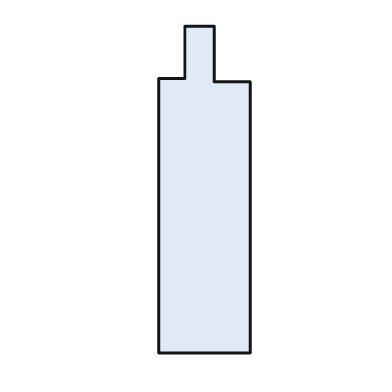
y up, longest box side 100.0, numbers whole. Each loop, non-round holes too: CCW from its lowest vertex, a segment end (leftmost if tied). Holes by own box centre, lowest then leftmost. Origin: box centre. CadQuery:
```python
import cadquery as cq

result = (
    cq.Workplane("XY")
    .moveTo(-14.0, -50.0)
    .lineTo(14.0, -50.0)
    .lineTo(14.0, 33.0)
    .lineTo(3.0, 33.0)
    .lineTo(3.0, 50.0)
    .lineTo(-6.0, 50.0)
    .lineTo(-6.0, 34.0)
    .lineTo(-14.0, 34.0)
    .close()
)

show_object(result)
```